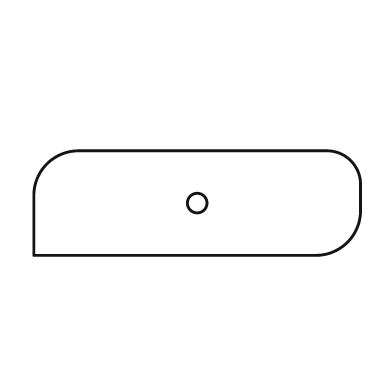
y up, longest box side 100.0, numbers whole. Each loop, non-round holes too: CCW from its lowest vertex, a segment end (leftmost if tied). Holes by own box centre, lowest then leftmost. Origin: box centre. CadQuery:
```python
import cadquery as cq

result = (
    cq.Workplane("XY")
    .moveTo(-50.0, -16.0)
    .lineTo(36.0, -16.0)
    .threePointArc((46.0, -12.0), (50.0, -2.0))
    .lineTo(50.0, 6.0)
    .threePointArc((47.0, 13.0), (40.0, 16.0))
    .lineTo(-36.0, 16.0)
    .threePointArc((-46.0, 12.0), (-50.0, 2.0))
    .close()
    .moveTo(0.0, 0.0)
    .circle(3.0)
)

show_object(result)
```